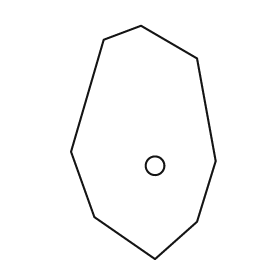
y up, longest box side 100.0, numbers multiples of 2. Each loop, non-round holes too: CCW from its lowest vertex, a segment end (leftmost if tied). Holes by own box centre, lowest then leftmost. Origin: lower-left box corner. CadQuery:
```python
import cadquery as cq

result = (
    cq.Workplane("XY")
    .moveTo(36.0, 0.0)
    .lineTo(54.0, 16.0)
    .lineTo(62.0, 42.0)
    .lineTo(54.0, 86.0)
    .lineTo(30.0, 100.0)
    .lineTo(14.0, 94.0)
    .lineTo(0.0, 46.0)
    .lineTo(10.0, 18.0)
    .close()
    .moveTo(36.0, 40.0)
    .circle(4.0)
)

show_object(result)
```